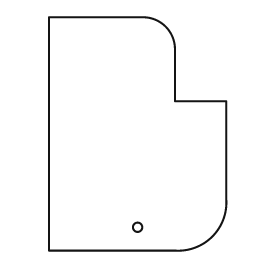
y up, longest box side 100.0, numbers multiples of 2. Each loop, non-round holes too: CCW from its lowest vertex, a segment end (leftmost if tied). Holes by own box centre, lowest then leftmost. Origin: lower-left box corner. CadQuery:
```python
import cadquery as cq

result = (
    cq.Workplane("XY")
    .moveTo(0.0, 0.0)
    .lineTo(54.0, 0.0)
    .threePointArc((70.0, 6.0), (76.0, 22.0))
    .lineTo(76.0, 64.0)
    .lineTo(54.0, 64.0)
    .lineTo(54.0, 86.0)
    .threePointArc((50.0, 96.0), (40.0, 100.0))
    .lineTo(0.0, 100.0)
    .close()
    .moveTo(38.0, 10.0)
    .circle(2.0)
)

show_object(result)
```